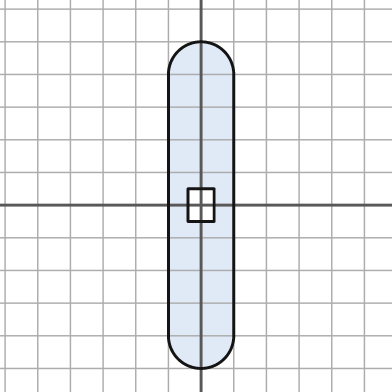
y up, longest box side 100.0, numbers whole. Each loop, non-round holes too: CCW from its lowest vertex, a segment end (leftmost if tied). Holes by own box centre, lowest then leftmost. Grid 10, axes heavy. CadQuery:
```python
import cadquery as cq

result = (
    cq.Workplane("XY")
    .moveTo(-10.0, -40.0)
    .threePointArc((0.0, -50.0), (10.0, -40.0))
    .lineTo(10.0, 40.0)
    .threePointArc((0.0, 50.0), (-10.0, 40.0))
    .close()
    .moveTo(-4.0, -5.0)
    .lineTo(4.0, -5.0)
    .lineTo(4.0, 5.0)
    .lineTo(-4.0, 5.0)
    .close()
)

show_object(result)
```